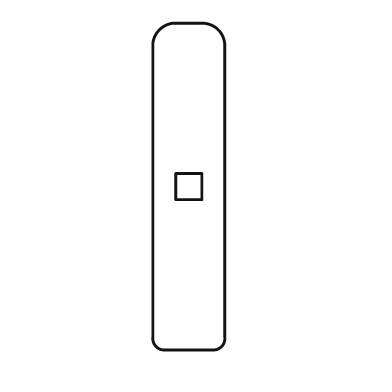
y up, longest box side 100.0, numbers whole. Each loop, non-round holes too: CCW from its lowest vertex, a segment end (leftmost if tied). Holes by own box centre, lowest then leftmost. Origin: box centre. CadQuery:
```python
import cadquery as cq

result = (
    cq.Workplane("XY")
    .moveTo(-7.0, -50.0)
    .lineTo(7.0, -50.0)
    .threePointArc((10.0, -49.0), (11.0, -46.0))
    .lineTo(11.0, 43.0)
    .threePointArc((9.0, 48.0), (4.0, 50.0))
    .lineTo(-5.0, 50.0)
    .threePointArc((-9.0, 48.0), (-11.0, 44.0))
    .lineTo(-11.0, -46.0)
    .threePointArc((-10.0, -49.0), (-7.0, -50.0))
    .close()
    .moveTo(-4.0, -4.0)
    .lineTo(4.0, -4.0)
    .lineTo(4.0, 4.0)
    .lineTo(-4.0, 4.0)
    .close()
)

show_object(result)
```